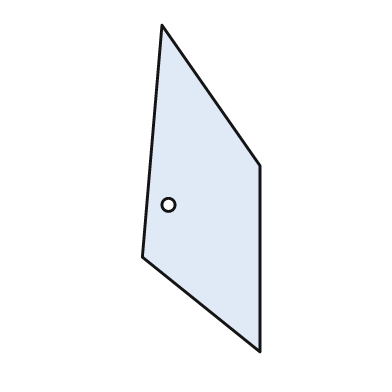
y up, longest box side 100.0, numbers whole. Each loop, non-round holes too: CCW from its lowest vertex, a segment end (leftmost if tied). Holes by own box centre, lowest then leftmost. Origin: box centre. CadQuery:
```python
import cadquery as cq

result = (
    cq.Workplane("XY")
    .moveTo(18.0, -50.0)
    .lineTo(18.0, 7.0)
    .lineTo(-12.0, 50.0)
    .lineTo(-18.0, -21.0)
    .close()
    .moveTo(-10.0, -5.0)
    .circle(2.0)
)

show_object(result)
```